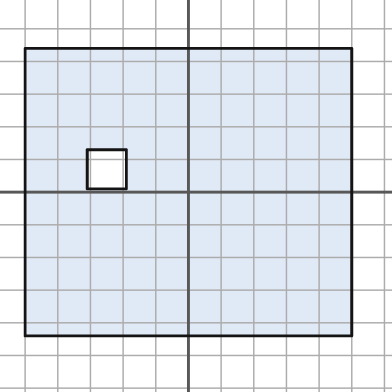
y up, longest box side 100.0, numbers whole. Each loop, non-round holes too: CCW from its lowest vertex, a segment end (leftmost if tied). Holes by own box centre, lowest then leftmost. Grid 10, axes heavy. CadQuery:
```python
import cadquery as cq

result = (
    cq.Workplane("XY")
    .moveTo(-50.0, -44.0)
    .lineTo(50.0, -44.0)
    .lineTo(50.0, 44.0)
    .lineTo(-50.0, 44.0)
    .close()
    .moveTo(-31.0, 1.0)
    .lineTo(-19.0, 1.0)
    .lineTo(-19.0, 13.0)
    .lineTo(-31.0, 13.0)
    .close()
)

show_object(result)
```